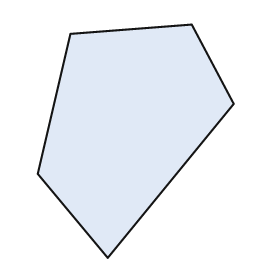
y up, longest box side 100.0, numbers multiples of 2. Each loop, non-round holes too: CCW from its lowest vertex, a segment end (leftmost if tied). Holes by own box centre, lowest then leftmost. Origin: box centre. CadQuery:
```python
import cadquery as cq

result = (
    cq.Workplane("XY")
    .moveTo(-12.0, -50.0)
    .lineTo(42.0, 16.0)
    .lineTo(24.0, 50.0)
    .lineTo(-28.0, 46.0)
    .lineTo(-42.0, -14.0)
    .close()
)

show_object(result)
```